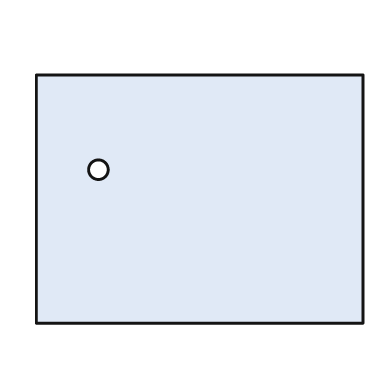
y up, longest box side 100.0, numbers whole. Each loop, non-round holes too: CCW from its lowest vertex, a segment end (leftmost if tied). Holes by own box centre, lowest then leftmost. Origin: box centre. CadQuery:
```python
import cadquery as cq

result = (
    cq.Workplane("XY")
    .moveTo(-50.0, -38.0)
    .lineTo(50.0, -38.0)
    .lineTo(50.0, 38.0)
    .lineTo(-50.0, 38.0)
    .close()
    .moveTo(-31.0, 9.0)
    .circle(3.0)
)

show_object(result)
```